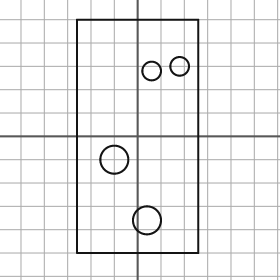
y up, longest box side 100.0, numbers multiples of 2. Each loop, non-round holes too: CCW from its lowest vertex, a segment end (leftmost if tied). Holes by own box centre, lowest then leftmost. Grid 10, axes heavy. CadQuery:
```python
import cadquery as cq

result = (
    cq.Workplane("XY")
    .moveTo(-26.0, -50.0)
    .lineTo(26.0, -50.0)
    .lineTo(26.0, 50.0)
    .lineTo(-26.0, 50.0)
    .close()
    .moveTo(4.0, -36.0)
    .circle(6.0)
    .moveTo(-10.0, -10.0)
    .circle(6.0)
    .moveTo(6.0, 28.0)
    .circle(4.0)
    .moveTo(18.0, 30.0)
    .circle(4.0)
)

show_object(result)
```